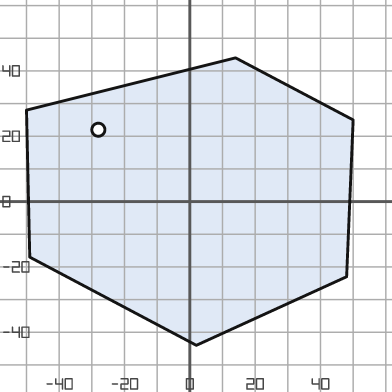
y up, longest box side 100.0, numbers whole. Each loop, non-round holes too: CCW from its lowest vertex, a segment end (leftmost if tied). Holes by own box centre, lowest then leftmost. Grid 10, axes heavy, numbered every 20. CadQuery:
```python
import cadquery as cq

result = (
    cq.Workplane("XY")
    .moveTo(2.0, -44.0)
    .lineTo(48.0, -23.0)
    .lineTo(50.0, 25.0)
    .lineTo(14.0, 44.0)
    .lineTo(-50.0, 28.0)
    .lineTo(-49.0, -17.0)
    .close()
    .moveTo(-28.0, 22.0)
    .circle(2.0)
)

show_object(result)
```